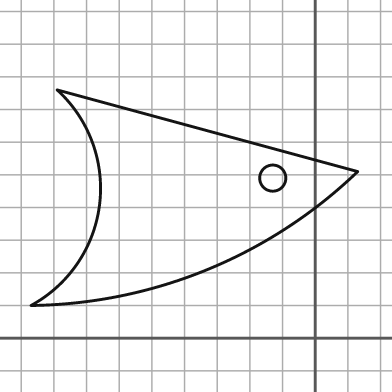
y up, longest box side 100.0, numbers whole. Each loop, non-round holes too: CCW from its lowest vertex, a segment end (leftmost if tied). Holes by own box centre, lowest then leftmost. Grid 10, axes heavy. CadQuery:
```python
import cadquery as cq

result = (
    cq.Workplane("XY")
    .moveTo(-87.0, 10.0)
    .threePointArc((-33.0, 21.0), (13.0, 51.0))
    .lineTo(-79.0, 76.0)
    .threePointArc((-66.0, 41.0), (-87.0, 10.0))
    .close()
    .moveTo(-13.0, 49.0)
    .circle(4.0)
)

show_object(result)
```